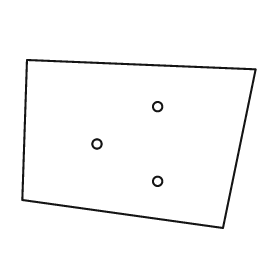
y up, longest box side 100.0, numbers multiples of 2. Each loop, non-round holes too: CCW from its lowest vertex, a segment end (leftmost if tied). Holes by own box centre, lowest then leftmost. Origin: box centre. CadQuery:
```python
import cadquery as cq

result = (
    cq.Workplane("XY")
    .moveTo(36.0, -36.0)
    .lineTo(50.0, 32.0)
    .lineTo(-48.0, 36.0)
    .lineTo(-50.0, -24.0)
    .close()
    .moveTo(8.0, -16.0)
    .circle(2.0)
    .moveTo(-18.0, 0.0)
    .circle(2.0)
    .moveTo(8.0, 16.0)
    .circle(2.0)
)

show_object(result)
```